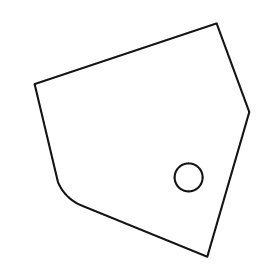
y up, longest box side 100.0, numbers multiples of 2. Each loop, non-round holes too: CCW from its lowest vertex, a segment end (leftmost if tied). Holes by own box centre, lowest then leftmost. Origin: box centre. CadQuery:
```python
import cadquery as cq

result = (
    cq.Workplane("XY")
    .moveTo(28.0, -50.0)
    .lineTo(46.0, 12.0)
    .lineTo(32.0, 50.0)
    .lineTo(-46.0, 24.0)
    .lineTo(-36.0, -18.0)
    .threePointArc((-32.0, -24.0), (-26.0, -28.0))
    .close()
    .moveTo(20.0, -16.0)
    .circle(6.0)
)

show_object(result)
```